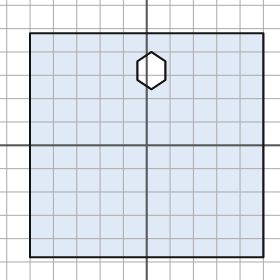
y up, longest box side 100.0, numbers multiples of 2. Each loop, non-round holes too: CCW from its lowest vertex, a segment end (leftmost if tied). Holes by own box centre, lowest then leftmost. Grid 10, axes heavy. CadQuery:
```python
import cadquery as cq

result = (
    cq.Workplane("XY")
    .moveTo(-50.0, -48.0)
    .lineTo(50.0, -48.0)
    .lineTo(50.0, 48.0)
    .lineTo(-50.0, 48.0)
    .close()
    .moveTo(2.0, 24.0)
    .lineTo(8.0, 28.0)
    .lineTo(8.0, 36.0)
    .lineTo(2.0, 40.0)
    .lineTo(-4.0, 36.0)
    .lineTo(-4.0, 28.0)
    .close()
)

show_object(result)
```